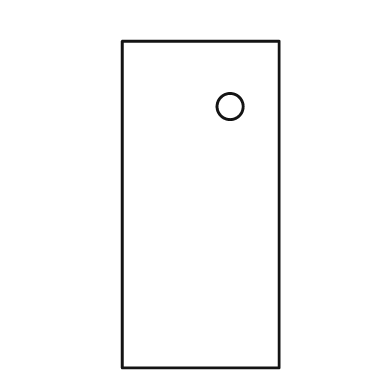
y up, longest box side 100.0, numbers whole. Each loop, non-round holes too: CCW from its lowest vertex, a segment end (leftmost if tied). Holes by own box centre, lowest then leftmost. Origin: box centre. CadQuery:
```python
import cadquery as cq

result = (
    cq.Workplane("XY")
    .moveTo(-24.0, -50.0)
    .lineTo(24.0, -50.0)
    .lineTo(24.0, 50.0)
    .lineTo(-24.0, 50.0)
    .close()
    .moveTo(9.0, 30.0)
    .circle(4.0)
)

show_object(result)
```